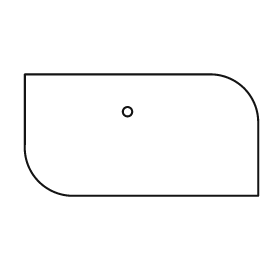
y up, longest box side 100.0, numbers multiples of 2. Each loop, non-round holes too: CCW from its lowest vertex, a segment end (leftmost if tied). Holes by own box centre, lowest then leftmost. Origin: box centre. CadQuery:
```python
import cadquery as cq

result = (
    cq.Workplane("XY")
    .moveTo(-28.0, -26.0)
    .lineTo(50.0, -26.0)
    .lineTo(50.0, 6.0)
    .threePointArc((44.0, 20.0), (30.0, 26.0))
    .lineTo(-50.0, 26.0)
    .lineTo(-50.0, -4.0)
    .threePointArc((-44.0, -20.0), (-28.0, -26.0))
    .close()
    .moveTo(-6.0, 10.0)
    .circle(2.0)
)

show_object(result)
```